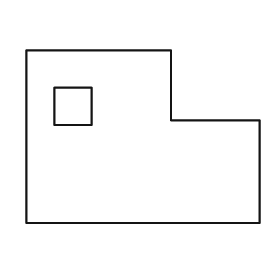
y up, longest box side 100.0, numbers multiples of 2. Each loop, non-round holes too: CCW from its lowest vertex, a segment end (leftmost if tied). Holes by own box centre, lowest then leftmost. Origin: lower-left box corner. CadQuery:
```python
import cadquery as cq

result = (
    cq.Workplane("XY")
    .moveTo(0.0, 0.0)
    .lineTo(100.0, 0.0)
    .lineTo(100.0, 44.0)
    .lineTo(62.0, 44.0)
    .lineTo(62.0, 74.0)
    .lineTo(0.0, 74.0)
    .close()
    .moveTo(12.0, 42.0)
    .lineTo(28.0, 42.0)
    .lineTo(28.0, 58.0)
    .lineTo(12.0, 58.0)
    .close()
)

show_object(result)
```